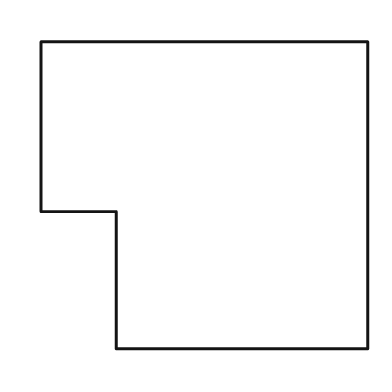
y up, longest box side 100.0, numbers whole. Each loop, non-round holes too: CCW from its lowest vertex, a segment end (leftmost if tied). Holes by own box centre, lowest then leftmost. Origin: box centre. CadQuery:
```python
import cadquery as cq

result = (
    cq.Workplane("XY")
    .moveTo(-27.0, -47.0)
    .lineTo(50.0, -47.0)
    .lineTo(50.0, 47.0)
    .lineTo(-50.0, 47.0)
    .lineTo(-50.0, -5.0)
    .lineTo(-27.0, -5.0)
    .close()
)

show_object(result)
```